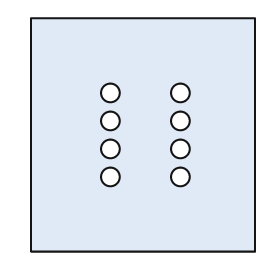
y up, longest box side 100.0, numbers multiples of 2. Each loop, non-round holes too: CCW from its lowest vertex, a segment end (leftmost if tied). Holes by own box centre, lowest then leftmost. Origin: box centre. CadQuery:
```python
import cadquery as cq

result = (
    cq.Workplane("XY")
    .moveTo(-48.0, -50.0)
    .lineTo(48.0, -50.0)
    .lineTo(48.0, 50.0)
    .lineTo(-48.0, 50.0)
    .close()
    .moveTo(-14.0, -18.0)
    .circle(4.0)
    .moveTo(16.0, -18.0)
    .circle(4.0)
    .moveTo(-14.0, -6.0)
    .circle(4.0)
    .moveTo(16.0, -6.0)
    .circle(4.0)
    .moveTo(-14.0, 6.0)
    .circle(4.0)
    .moveTo(16.0, 6.0)
    .circle(4.0)
    .moveTo(-14.0, 18.0)
    .circle(4.0)
    .moveTo(16.0, 18.0)
    .circle(4.0)
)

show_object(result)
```